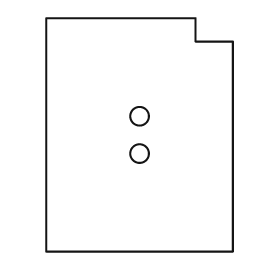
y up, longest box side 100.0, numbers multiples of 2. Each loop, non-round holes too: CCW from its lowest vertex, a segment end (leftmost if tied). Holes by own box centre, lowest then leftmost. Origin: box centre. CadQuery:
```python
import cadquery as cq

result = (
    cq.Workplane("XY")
    .moveTo(-40.0, -50.0)
    .lineTo(40.0, -50.0)
    .lineTo(40.0, 40.0)
    .lineTo(24.0, 40.0)
    .lineTo(24.0, 50.0)
    .lineTo(-40.0, 50.0)
    .close()
    .moveTo(0.0, -8.0)
    .circle(4.0)
    .moveTo(0.0, 8.0)
    .circle(4.0)
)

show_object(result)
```